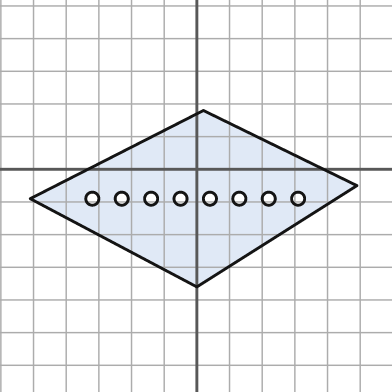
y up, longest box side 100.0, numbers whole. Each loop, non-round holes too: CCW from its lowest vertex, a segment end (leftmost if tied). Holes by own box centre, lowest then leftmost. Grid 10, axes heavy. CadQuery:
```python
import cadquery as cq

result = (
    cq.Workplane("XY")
    .moveTo(0.0, -36.0)
    .lineTo(49.0, -5.0)
    .lineTo(2.0, 18.0)
    .lineTo(-51.0, -9.0)
    .close()
    .moveTo(-32.0, -9.0)
    .circle(2.0)
    .moveTo(-23.0, -9.0)
    .circle(2.0)
    .moveTo(-14.0, -9.0)
    .circle(2.0)
    .moveTo(-5.0, -9.0)
    .circle(2.0)
    .moveTo(4.0, -9.0)
    .circle(2.0)
    .moveTo(13.0, -9.0)
    .circle(2.0)
    .moveTo(22.0, -9.0)
    .circle(2.0)
    .moveTo(31.0, -9.0)
    .circle(2.0)
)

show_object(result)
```